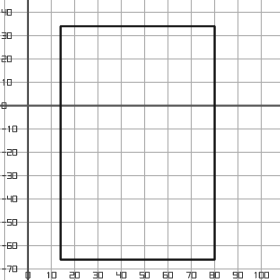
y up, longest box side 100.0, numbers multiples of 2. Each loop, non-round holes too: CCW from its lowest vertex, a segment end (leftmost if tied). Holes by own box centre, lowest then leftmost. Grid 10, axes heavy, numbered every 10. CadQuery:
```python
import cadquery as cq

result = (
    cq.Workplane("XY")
    .moveTo(14.0, -66.0)
    .lineTo(80.0, -66.0)
    .lineTo(80.0, 34.0)
    .lineTo(14.0, 34.0)
    .close()
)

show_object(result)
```